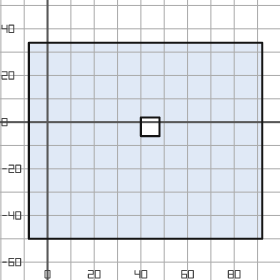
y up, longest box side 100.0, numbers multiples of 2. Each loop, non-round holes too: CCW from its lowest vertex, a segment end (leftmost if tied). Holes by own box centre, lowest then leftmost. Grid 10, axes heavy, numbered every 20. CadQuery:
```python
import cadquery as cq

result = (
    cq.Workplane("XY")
    .moveTo(-8.0, -50.0)
    .lineTo(92.0, -50.0)
    .lineTo(92.0, 34.0)
    .lineTo(-8.0, 34.0)
    .close()
    .moveTo(40.0, -6.0)
    .lineTo(48.0, -6.0)
    .lineTo(48.0, 2.0)
    .lineTo(40.0, 2.0)
    .close()
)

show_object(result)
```